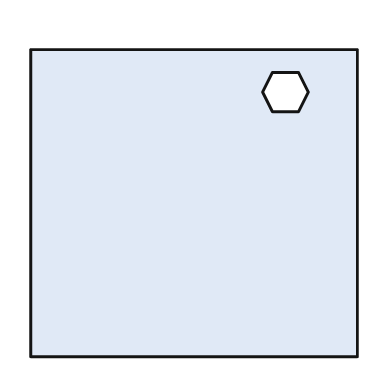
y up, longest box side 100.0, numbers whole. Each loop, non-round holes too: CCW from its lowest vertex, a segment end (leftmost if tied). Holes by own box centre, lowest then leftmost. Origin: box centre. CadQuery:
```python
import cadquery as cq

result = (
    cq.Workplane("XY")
    .moveTo(-50.0, -47.0)
    .lineTo(50.0, -47.0)
    .lineTo(50.0, 47.0)
    .lineTo(-50.0, 47.0)
    .close()
    .moveTo(24.0, 28.0)
    .lineTo(32.0, 28.0)
    .lineTo(35.0, 34.0)
    .lineTo(32.0, 40.0)
    .lineTo(24.0, 40.0)
    .lineTo(21.0, 34.0)
    .close()
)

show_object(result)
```